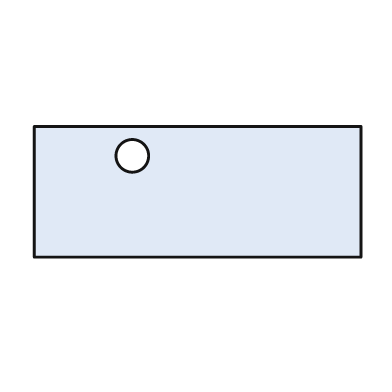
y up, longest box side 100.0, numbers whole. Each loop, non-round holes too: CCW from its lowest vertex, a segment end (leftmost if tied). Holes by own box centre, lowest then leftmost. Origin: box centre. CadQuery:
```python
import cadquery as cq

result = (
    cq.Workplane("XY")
    .moveTo(-50.0, -20.0)
    .lineTo(50.0, -20.0)
    .lineTo(50.0, 20.0)
    .lineTo(-50.0, 20.0)
    .close()
    .moveTo(-20.0, 11.0)
    .circle(5.0)
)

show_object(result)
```